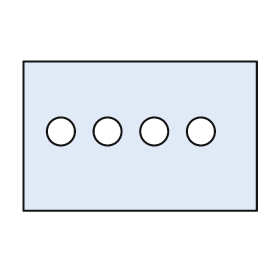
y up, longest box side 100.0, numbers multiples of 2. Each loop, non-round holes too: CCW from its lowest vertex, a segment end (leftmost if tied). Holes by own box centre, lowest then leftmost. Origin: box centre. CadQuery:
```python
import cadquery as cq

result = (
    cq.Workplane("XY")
    .moveTo(-50.0, -32.0)
    .lineTo(50.0, -32.0)
    .lineTo(50.0, 32.0)
    .lineTo(-50.0, 32.0)
    .close()
    .moveTo(-34.0, 2.0)
    .circle(6.0)
    .moveTo(-14.0, 2.0)
    .circle(6.0)
    .moveTo(6.0, 2.0)
    .circle(6.0)
    .moveTo(26.0, 2.0)
    .circle(6.0)
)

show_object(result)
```